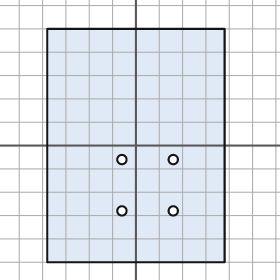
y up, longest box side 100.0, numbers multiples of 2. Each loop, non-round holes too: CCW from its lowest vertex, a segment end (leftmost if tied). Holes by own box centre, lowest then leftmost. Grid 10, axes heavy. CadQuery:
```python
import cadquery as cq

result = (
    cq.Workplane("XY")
    .moveTo(-38.0, -50.0)
    .lineTo(38.0, -50.0)
    .lineTo(38.0, 50.0)
    .lineTo(-38.0, 50.0)
    .close()
    .moveTo(-6.0, -28.0)
    .circle(2.0)
    .moveTo(16.0, -28.0)
    .circle(2.0)
    .moveTo(-6.0, -6.0)
    .circle(2.0)
    .moveTo(16.0, -6.0)
    .circle(2.0)
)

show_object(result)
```